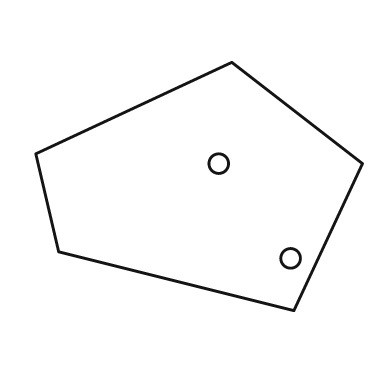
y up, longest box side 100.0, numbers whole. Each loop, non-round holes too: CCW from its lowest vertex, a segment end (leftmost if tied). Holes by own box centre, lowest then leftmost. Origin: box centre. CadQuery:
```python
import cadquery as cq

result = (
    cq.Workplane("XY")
    .moveTo(29.0, -38.0)
    .lineTo(50.0, 7.0)
    .lineTo(10.0, 38.0)
    .lineTo(-50.0, 10.0)
    .lineTo(-43.0, -20.0)
    .close()
    .moveTo(28.0, -22.0)
    .circle(3.0)
    .moveTo(6.0, 7.0)
    .circle(3.0)
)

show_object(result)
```